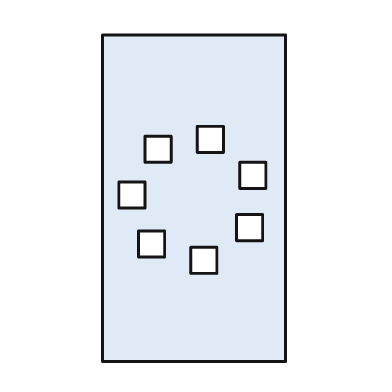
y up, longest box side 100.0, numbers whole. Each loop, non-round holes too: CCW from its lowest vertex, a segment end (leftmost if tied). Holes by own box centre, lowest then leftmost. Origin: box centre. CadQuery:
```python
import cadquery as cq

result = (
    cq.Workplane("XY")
    .moveTo(-28.0, -50.0)
    .lineTo(28.0, -50.0)
    .lineTo(28.0, 50.0)
    .lineTo(-28.0, 50.0)
    .close()
    .moveTo(-1.0, -23.0)
    .lineTo(7.0, -23.0)
    .lineTo(7.0, -15.0)
    .lineTo(-1.0, -15.0)
    .close()
    .moveTo(-17.0, -18.0)
    .lineTo(-9.0, -18.0)
    .lineTo(-9.0, -10.0)
    .lineTo(-17.0, -10.0)
    .close()
    .moveTo(13.0, -13.0)
    .lineTo(21.0, -13.0)
    .lineTo(21.0, -5.0)
    .lineTo(13.0, -5.0)
    .close()
    .moveTo(-23.0, -3.0)
    .lineTo(-15.0, -3.0)
    .lineTo(-15.0, 5.0)
    .lineTo(-23.0, 5.0)
    .close()
    .moveTo(14.0, 3.0)
    .lineTo(22.0, 3.0)
    .lineTo(22.0, 11.0)
    .lineTo(14.0, 11.0)
    .close()
    .moveTo(-15.0, 11.0)
    .lineTo(-7.0, 11.0)
    .lineTo(-7.0, 19.0)
    .lineTo(-15.0, 19.0)
    .close()
    .moveTo(1.0, 14.0)
    .lineTo(9.0, 14.0)
    .lineTo(9.0, 22.0)
    .lineTo(1.0, 22.0)
    .close()
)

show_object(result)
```